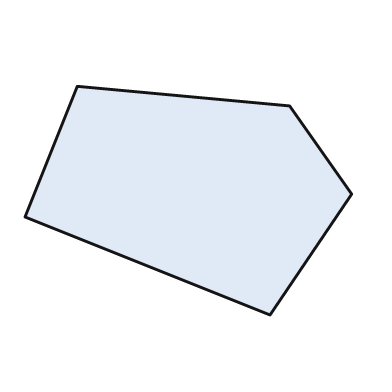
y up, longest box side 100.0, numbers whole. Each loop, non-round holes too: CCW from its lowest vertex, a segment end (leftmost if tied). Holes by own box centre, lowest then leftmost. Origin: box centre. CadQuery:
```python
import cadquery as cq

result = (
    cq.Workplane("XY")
    .moveTo(25.0, -35.0)
    .lineTo(50.0, 2.0)
    .lineTo(31.0, 29.0)
    .lineTo(-34.0, 35.0)
    .lineTo(-50.0, -5.0)
    .close()
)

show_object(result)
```